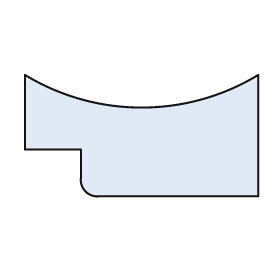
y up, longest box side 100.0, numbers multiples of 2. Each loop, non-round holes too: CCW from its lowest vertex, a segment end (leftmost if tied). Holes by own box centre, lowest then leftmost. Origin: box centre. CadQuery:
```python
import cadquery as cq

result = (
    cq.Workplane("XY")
    .moveTo(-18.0, -26.0)
    .lineTo(50.0, -26.0)
    .lineTo(50.0, 26.0)
    .threePointArc((0.0, 12.0), (-50.0, 26.0))
    .lineTo(-50.0, -6.0)
    .lineTo(-26.0, -6.0)
    .lineTo(-26.0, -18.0)
    .threePointArc((-24.0, -24.0), (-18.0, -26.0))
    .close()
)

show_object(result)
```